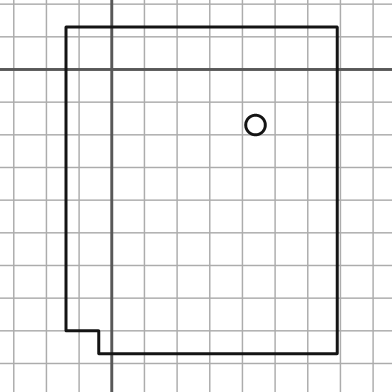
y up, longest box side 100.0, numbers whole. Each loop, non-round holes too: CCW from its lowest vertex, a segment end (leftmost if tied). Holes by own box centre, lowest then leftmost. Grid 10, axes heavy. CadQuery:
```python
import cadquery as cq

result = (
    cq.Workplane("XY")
    .moveTo(-4.0, -87.0)
    .lineTo(69.0, -87.0)
    .lineTo(69.0, 13.0)
    .lineTo(-14.0, 13.0)
    .lineTo(-14.0, -80.0)
    .lineTo(-4.0, -80.0)
    .close()
    .moveTo(44.0, -17.0)
    .circle(3.0)
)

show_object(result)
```